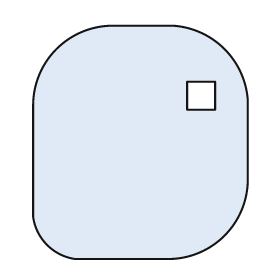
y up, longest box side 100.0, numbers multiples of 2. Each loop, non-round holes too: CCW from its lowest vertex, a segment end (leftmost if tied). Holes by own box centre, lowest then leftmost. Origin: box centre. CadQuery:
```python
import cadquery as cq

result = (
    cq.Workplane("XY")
    .moveTo(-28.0, -50.0)
    .lineTo(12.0, -50.0)
    .threePointArc((36.0, -40.0), (46.0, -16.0))
    .lineTo(46.0, 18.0)
    .threePointArc((36.0, 40.0), (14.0, 50.0))
    .lineTo(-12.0, 50.0)
    .threePointArc((-36.0, 40.0), (-46.0, 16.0))
    .lineTo(-46.0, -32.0)
    .threePointArc((-40.0, -44.0), (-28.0, -50.0))
    .close()
    .moveTo(20.0, 14.0)
    .lineTo(32.0, 14.0)
    .lineTo(32.0, 26.0)
    .lineTo(20.0, 26.0)
    .close()
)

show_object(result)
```